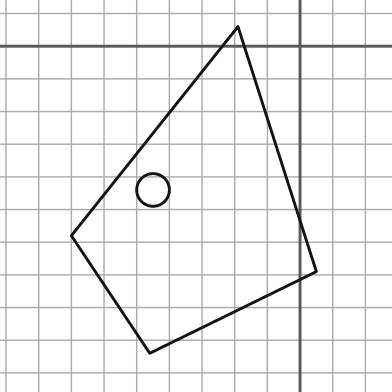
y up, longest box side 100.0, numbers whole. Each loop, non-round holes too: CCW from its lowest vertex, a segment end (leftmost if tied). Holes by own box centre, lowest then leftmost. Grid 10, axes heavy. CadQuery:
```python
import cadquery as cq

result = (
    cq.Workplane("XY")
    .moveTo(-46.0, -94.0)
    .lineTo(5.0, -69.0)
    .lineTo(-19.0, 6.0)
    .lineTo(-70.0, -58.0)
    .close()
    .moveTo(-45.0, -44.0)
    .circle(5.0)
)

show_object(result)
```